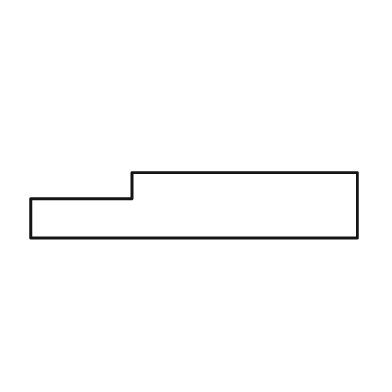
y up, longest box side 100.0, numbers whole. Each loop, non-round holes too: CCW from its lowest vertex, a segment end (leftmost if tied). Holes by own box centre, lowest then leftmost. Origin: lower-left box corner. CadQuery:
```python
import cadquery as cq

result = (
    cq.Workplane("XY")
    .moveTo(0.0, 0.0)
    .lineTo(100.0, 0.0)
    .lineTo(100.0, 20.0)
    .lineTo(31.0, 20.0)
    .lineTo(31.0, 12.0)
    .lineTo(0.0, 12.0)
    .close()
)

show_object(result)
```